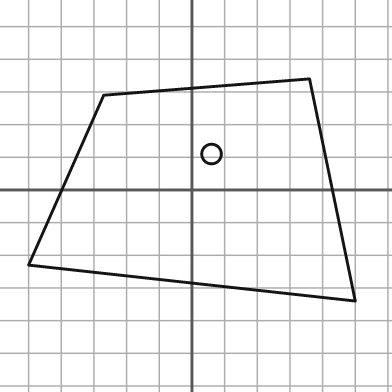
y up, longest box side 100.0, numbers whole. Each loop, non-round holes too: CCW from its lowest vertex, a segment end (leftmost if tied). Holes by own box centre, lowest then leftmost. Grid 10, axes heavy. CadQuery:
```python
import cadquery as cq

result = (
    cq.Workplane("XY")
    .moveTo(50.0, -34.0)
    .lineTo(36.0, 34.0)
    .lineTo(-27.0, 29.0)
    .lineTo(-50.0, -23.0)
    .close()
    .moveTo(6.0, 11.0)
    .circle(3.0)
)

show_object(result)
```